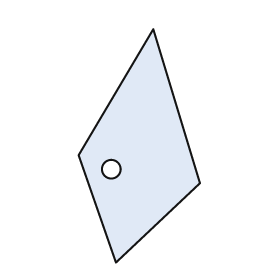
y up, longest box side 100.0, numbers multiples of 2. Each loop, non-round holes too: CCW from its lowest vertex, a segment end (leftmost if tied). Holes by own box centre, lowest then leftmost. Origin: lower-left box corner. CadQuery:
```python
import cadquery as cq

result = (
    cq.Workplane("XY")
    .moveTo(16.0, 0.0)
    .lineTo(52.0, 34.0)
    .lineTo(32.0, 100.0)
    .lineTo(0.0, 46.0)
    .close()
    .moveTo(14.0, 40.0)
    .circle(4.0)
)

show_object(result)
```